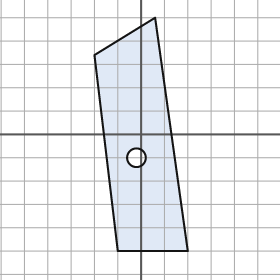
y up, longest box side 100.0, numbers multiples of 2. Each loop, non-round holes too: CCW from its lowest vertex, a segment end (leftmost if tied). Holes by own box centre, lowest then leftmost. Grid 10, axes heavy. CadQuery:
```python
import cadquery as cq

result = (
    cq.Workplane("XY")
    .moveTo(-10.0, -50.0)
    .lineTo(20.0, -50.0)
    .lineTo(6.0, 50.0)
    .lineTo(-20.0, 34.0)
    .close()
    .moveTo(-2.0, -10.0)
    .circle(4.0)
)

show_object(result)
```